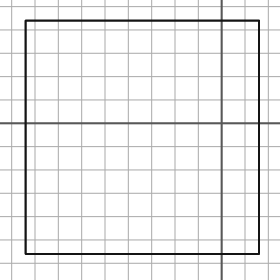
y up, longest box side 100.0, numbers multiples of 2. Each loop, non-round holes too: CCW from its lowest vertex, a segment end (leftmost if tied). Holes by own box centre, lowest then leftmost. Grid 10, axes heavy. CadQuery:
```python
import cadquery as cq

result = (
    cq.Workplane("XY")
    .moveTo(-84.0, -56.0)
    .lineTo(16.0, -56.0)
    .lineTo(16.0, 44.0)
    .lineTo(-84.0, 44.0)
    .close()
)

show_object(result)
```